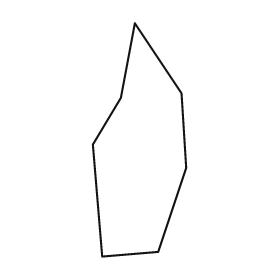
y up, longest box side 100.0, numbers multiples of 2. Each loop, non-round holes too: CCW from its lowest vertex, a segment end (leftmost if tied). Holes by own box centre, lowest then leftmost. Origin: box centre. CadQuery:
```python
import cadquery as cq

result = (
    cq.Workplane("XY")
    .moveTo(-16.0, -50.0)
    .lineTo(8.0, -48.0)
    .lineTo(20.0, -12.0)
    .lineTo(18.0, 20.0)
    .lineTo(-2.0, 50.0)
    .lineTo(-8.0, 18.0)
    .lineTo(-20.0, -2.0)
    .close()
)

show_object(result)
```